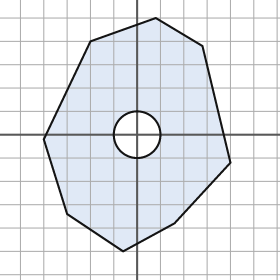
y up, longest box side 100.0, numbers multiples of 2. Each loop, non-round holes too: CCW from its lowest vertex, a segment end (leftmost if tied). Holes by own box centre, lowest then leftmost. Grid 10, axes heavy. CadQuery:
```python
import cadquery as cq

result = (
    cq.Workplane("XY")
    .moveTo(-6.0, -50.0)
    .lineTo(16.0, -38.0)
    .lineTo(40.0, -12.0)
    .lineTo(28.0, 38.0)
    .lineTo(8.0, 50.0)
    .lineTo(-20.0, 40.0)
    .lineTo(-40.0, -2.0)
    .lineTo(-30.0, -34.0)
    .close()
    .moveTo(0.0, 0.0)
    .circle(10.0)
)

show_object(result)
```